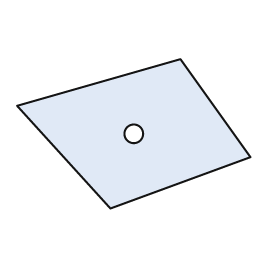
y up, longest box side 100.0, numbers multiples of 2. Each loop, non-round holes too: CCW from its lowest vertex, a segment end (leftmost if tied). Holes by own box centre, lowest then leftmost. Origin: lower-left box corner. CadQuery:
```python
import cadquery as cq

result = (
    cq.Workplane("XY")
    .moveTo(40.0, 0.0)
    .lineTo(100.0, 22.0)
    .lineTo(70.0, 64.0)
    .lineTo(0.0, 44.0)
    .close()
    .moveTo(50.0, 32.0)
    .circle(4.0)
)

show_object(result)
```